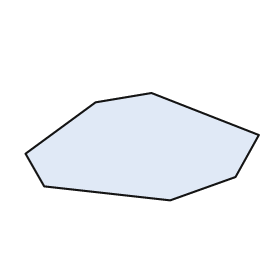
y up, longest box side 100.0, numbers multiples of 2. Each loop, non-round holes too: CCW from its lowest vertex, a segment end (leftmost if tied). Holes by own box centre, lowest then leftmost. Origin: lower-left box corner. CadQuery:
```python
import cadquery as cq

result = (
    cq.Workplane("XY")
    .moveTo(62.0, 0.0)
    .lineTo(90.0, 10.0)
    .lineTo(100.0, 28.0)
    .lineTo(54.0, 46.0)
    .lineTo(30.0, 42.0)
    .lineTo(0.0, 20.0)
    .lineTo(8.0, 6.0)
    .close()
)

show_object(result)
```